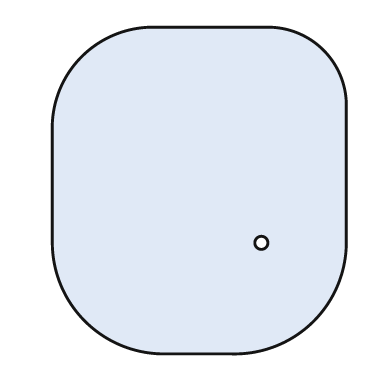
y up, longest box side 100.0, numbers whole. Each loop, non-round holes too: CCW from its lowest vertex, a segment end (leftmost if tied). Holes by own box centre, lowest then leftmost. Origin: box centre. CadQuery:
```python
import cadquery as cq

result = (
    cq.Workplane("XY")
    .moveTo(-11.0, -50.0)
    .lineTo(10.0, -50.0)
    .threePointArc((35.0, -40.0), (45.0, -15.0))
    .lineTo(45.0, 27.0)
    .threePointArc((38.0, 43.0), (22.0, 50.0))
    .lineTo(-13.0, 50.0)
    .threePointArc((-36.0, 41.0), (-45.0, 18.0))
    .lineTo(-45.0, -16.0)
    .threePointArc((-35.0, -40.0), (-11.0, -50.0))
    .close()
    .moveTo(19.0, -16.0)
    .circle(2.0)
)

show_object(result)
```